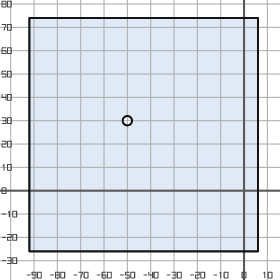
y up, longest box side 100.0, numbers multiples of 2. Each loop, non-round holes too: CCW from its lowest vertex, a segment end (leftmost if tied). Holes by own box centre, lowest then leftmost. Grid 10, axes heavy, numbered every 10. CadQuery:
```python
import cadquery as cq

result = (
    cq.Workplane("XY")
    .moveTo(-92.0, -26.0)
    .lineTo(6.0, -26.0)
    .lineTo(6.0, 74.0)
    .lineTo(-92.0, 74.0)
    .close()
    .moveTo(-50.0, 30.0)
    .circle(2.0)
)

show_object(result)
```